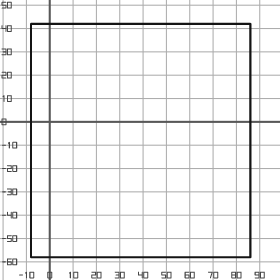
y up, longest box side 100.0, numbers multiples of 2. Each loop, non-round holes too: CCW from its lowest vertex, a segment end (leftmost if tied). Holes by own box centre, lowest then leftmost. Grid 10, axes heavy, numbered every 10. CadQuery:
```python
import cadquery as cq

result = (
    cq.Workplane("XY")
    .moveTo(-8.0, -58.0)
    .lineTo(86.0, -58.0)
    .lineTo(86.0, 42.0)
    .lineTo(-8.0, 42.0)
    .close()
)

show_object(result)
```